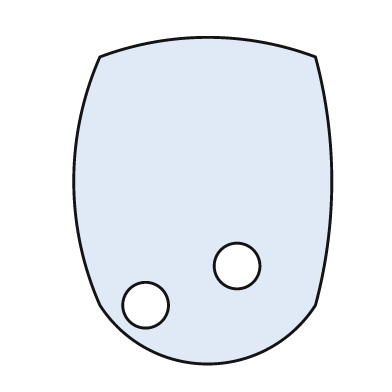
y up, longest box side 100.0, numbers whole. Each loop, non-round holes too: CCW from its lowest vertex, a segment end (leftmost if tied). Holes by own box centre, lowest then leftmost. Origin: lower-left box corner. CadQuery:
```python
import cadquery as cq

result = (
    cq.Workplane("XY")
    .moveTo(8.0, 18.0)
    .threePointArc((41.0, 0.0), (74.0, 18.0))
    .threePointArc((79.0, 56.0), (74.0, 94.0))
    .threePointArc((41.0, 100.0), (8.0, 94.0))
    .threePointArc((0.0, 56.0), (8.0, 18.0))
    .close()
    .moveTo(22.0, 18.0)
    .circle(7.0)
    .moveTo(50.0, 30.0)
    .circle(7.0)
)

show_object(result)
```